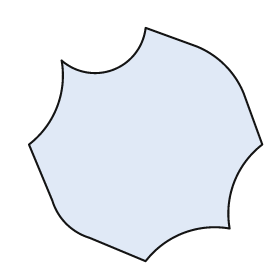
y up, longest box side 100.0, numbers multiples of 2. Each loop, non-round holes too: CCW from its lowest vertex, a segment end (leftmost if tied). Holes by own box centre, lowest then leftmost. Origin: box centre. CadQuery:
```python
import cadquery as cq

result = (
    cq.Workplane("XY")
    .moveTo(0.0, -50.0)
    .threePointArc((16.0, -38.0), (36.0, -36.0))
    .threePointArc((38.0, -16.0), (50.0, 0.0))
    .lineTo(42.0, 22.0)
    .threePointArc((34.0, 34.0), (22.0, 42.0))
    .lineTo(0.0, 50.0)
    .threePointArc((-14.0, 32.0), (-36.0, 36.0))
    .threePointArc((-38.0, 16.0), (-50.0, 0.0))
    .lineTo(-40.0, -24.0)
    .threePointArc((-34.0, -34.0), (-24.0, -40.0))
    .close()
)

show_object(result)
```